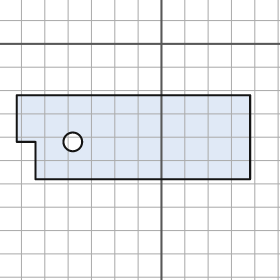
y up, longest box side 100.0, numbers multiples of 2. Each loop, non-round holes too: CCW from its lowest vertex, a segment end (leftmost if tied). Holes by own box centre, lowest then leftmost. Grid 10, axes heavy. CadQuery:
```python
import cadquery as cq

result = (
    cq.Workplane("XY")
    .moveTo(-54.0, -58.0)
    .lineTo(38.0, -58.0)
    .lineTo(38.0, -22.0)
    .lineTo(-62.0, -22.0)
    .lineTo(-62.0, -42.0)
    .lineTo(-54.0, -42.0)
    .close()
    .moveTo(-38.0, -42.0)
    .circle(4.0)
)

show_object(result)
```